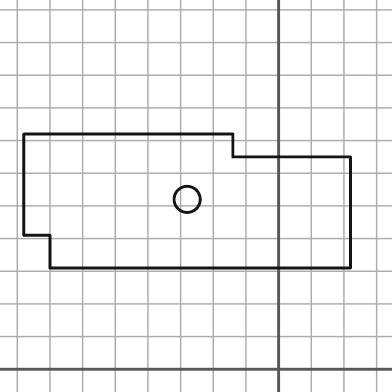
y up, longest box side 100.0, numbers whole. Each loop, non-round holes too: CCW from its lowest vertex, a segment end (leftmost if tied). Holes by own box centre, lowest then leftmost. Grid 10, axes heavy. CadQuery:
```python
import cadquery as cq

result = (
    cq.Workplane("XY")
    .moveTo(-70.0, 31.0)
    .lineTo(22.0, 31.0)
    .lineTo(22.0, 65.0)
    .lineTo(-14.0, 65.0)
    .lineTo(-14.0, 72.0)
    .lineTo(-78.0, 72.0)
    .lineTo(-78.0, 41.0)
    .lineTo(-70.0, 41.0)
    .close()
    .moveTo(-28.0, 52.0)
    .circle(4.0)
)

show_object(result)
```